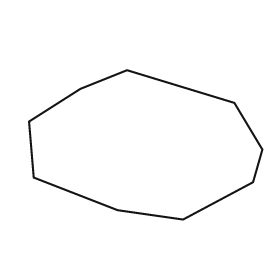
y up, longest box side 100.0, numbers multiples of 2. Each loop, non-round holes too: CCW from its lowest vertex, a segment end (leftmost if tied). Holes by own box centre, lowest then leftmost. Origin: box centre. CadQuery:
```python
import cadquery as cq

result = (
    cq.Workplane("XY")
    .moveTo(16.0, -32.0)
    .lineTo(46.0, -16.0)
    .lineTo(50.0, -2.0)
    .lineTo(38.0, 18.0)
    .lineTo(-8.0, 32.0)
    .lineTo(-28.0, 24.0)
    .lineTo(-50.0, 10.0)
    .lineTo(-48.0, -14.0)
    .lineTo(-12.0, -28.0)
    .close()
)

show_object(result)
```